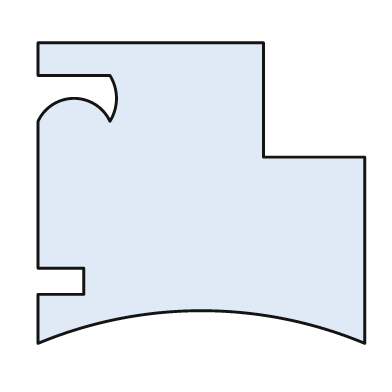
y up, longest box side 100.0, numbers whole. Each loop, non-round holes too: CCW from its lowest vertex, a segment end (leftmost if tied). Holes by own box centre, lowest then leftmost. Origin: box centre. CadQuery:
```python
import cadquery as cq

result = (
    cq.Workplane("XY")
    .moveTo(-50.0, -46.0)
    .threePointArc((0.0, -36.0), (50.0, -46.0))
    .lineTo(50.0, 11.0)
    .lineTo(19.0, 11.0)
    .lineTo(19.0, 46.0)
    .lineTo(-50.0, 46.0)
    .lineTo(-50.0, 36.0)
    .lineTo(-28.0, 36.0)
    .threePointArc((-26.0, 29.0), (-28.0, 22.0))
    .threePointArc((-39.0, 29.0), (-50.0, 22.0))
    .lineTo(-50.0, -23.0)
    .lineTo(-36.0, -23.0)
    .lineTo(-36.0, -31.0)
    .lineTo(-50.0, -31.0)
    .close()
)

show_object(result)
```